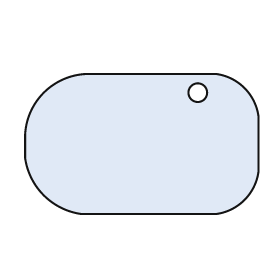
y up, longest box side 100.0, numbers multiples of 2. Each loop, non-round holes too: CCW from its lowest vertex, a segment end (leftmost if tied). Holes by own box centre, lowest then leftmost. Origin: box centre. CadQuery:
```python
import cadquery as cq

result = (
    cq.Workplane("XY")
    .moveTo(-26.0, -30.0)
    .lineTo(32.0, -30.0)
    .threePointArc((44.0, -24.0), (50.0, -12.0))
    .lineTo(50.0, 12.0)
    .threePointArc((44.0, 24.0), (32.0, 30.0))
    .lineTo(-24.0, 30.0)
    .threePointArc((-42.0, 22.0), (-50.0, 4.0))
    .lineTo(-50.0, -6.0)
    .threePointArc((-42.0, -22.0), (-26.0, -30.0))
    .close()
    .moveTo(24.0, 22.0)
    .circle(4.0)
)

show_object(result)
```